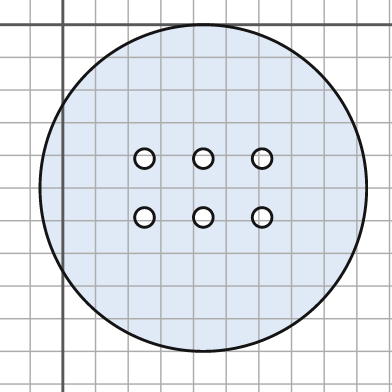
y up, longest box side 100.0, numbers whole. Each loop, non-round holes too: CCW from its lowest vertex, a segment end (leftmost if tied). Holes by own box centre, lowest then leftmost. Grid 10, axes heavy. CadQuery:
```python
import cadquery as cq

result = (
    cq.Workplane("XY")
    .moveTo(43.0, -50.0)
    .circle(50.0)
    .moveTo(25.0, -59.0)
    .circle(3.0)
    .moveTo(43.0, -59.0)
    .circle(3.0)
    .moveTo(61.0, -59.0)
    .circle(3.0)
    .moveTo(25.0, -41.0)
    .circle(3.0)
    .moveTo(43.0, -41.0)
    .circle(3.0)
    .moveTo(61.0, -41.0)
    .circle(3.0)
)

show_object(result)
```